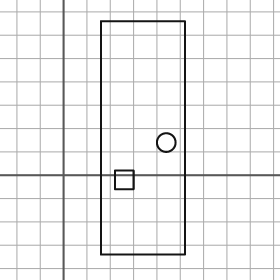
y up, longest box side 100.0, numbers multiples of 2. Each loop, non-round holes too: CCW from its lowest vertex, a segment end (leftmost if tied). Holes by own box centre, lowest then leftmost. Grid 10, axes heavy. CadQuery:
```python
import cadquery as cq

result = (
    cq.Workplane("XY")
    .moveTo(16.0, -34.0)
    .lineTo(52.0, -34.0)
    .lineTo(52.0, 66.0)
    .lineTo(16.0, 66.0)
    .close()
    .moveTo(22.0, -6.0)
    .lineTo(30.0, -6.0)
    .lineTo(30.0, 2.0)
    .lineTo(22.0, 2.0)
    .close()
    .moveTo(44.0, 14.0)
    .circle(4.0)
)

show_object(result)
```